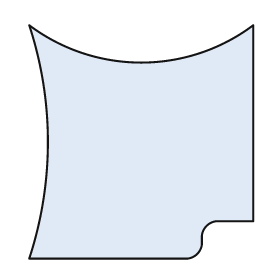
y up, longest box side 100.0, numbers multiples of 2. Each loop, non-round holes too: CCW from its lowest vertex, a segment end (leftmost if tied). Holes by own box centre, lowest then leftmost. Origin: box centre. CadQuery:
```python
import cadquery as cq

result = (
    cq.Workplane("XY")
    .moveTo(-48.0, -50.0)
    .lineTo(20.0, -50.0)
    .threePointArc((24.0, -48.0), (26.0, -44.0))
    .lineTo(26.0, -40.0)
    .threePointArc((28.0, -36.0), (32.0, -34.0))
    .lineTo(48.0, -34.0)
    .lineTo(48.0, 50.0)
    .threePointArc((0.0, 34.0), (-48.0, 50.0))
    .threePointArc((-40.0, 0.0), (-48.0, -50.0))
    .close()
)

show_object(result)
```